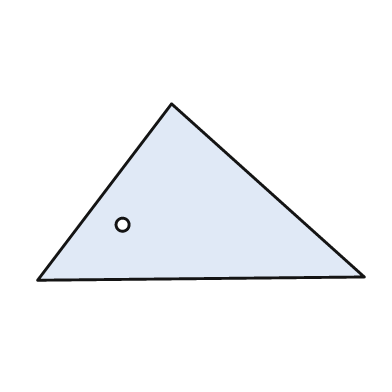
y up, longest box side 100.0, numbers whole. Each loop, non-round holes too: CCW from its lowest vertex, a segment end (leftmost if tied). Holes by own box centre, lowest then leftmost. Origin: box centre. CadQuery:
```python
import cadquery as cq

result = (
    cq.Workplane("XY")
    .moveTo(-50.0, -27.0)
    .lineTo(50.0, -26.0)
    .lineTo(-9.0, 27.0)
    .close()
    .moveTo(-24.0, -10.0)
    .circle(2.0)
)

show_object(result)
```